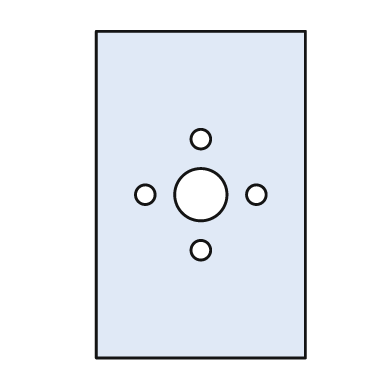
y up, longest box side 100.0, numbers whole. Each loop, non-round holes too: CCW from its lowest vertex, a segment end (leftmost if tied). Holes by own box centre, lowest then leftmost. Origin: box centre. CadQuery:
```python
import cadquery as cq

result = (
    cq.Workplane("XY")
    .moveTo(-32.0, -50.0)
    .lineTo(32.0, -50.0)
    .lineTo(32.0, 50.0)
    .lineTo(-32.0, 50.0)
    .close()
    .moveTo(0.0, -17.0)
    .circle(3.0)
    .moveTo(-17.0, 0.0)
    .circle(3.0)
    .moveTo(0.0, 0.0)
    .circle(8.0)
    .moveTo(17.0, 0.0)
    .circle(3.0)
    .moveTo(0.0, 17.0)
    .circle(3.0)
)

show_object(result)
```